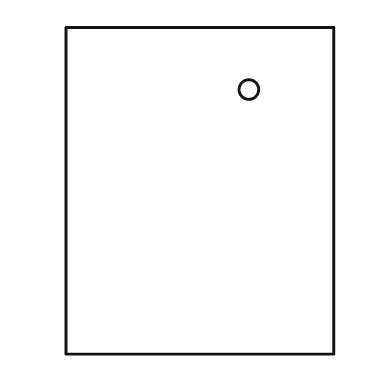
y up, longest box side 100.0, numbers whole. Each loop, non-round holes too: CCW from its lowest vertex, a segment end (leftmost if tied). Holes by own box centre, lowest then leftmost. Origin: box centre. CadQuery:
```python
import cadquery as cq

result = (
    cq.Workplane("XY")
    .moveTo(-41.0, -50.0)
    .lineTo(41.0, -50.0)
    .lineTo(41.0, 50.0)
    .lineTo(-41.0, 50.0)
    .close()
    .moveTo(15.0, 31.0)
    .circle(3.0)
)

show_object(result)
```